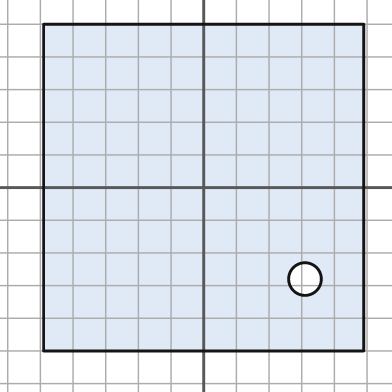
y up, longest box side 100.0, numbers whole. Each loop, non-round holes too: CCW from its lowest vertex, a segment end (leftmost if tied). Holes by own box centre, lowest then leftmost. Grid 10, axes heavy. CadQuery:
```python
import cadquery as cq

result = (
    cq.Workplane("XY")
    .moveTo(-49.0, -50.0)
    .lineTo(49.0, -50.0)
    .lineTo(49.0, 50.0)
    .lineTo(-49.0, 50.0)
    .close()
    .moveTo(31.0, -28.0)
    .circle(5.0)
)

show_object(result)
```